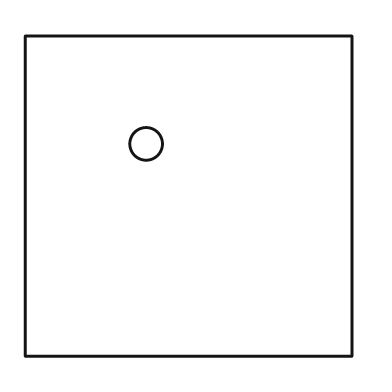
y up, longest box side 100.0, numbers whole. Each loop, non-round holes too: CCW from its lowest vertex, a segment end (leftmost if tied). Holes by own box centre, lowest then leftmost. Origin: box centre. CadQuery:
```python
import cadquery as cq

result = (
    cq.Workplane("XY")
    .moveTo(-50.0, -49.0)
    .lineTo(50.0, -49.0)
    .lineTo(50.0, 49.0)
    .lineTo(-50.0, 49.0)
    .close()
    .moveTo(-13.0, 16.0)
    .circle(5.0)
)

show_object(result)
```